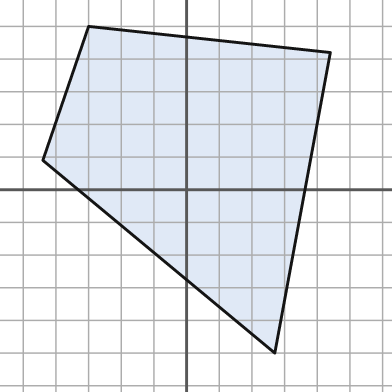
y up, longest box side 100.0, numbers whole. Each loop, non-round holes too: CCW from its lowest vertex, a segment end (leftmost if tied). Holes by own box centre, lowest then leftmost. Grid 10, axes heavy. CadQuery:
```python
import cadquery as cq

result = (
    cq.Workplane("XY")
    .moveTo(27.0, -50.0)
    .lineTo(44.0, 42.0)
    .lineTo(-30.0, 50.0)
    .lineTo(-44.0, 9.0)
    .close()
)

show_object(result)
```